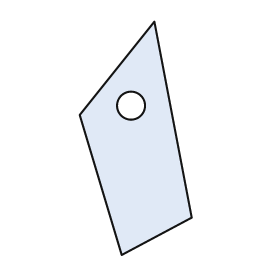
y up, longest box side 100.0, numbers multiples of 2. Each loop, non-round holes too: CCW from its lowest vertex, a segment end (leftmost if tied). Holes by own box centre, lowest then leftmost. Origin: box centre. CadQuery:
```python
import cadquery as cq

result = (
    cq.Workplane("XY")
    .moveTo(-6.0, -50.0)
    .lineTo(24.0, -34.0)
    .lineTo(8.0, 50.0)
    .lineTo(-24.0, 10.0)
    .close()
    .moveTo(-2.0, 14.0)
    .circle(6.0)
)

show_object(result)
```